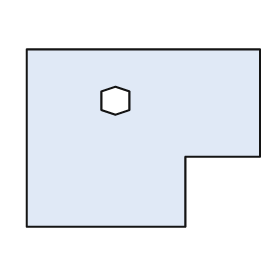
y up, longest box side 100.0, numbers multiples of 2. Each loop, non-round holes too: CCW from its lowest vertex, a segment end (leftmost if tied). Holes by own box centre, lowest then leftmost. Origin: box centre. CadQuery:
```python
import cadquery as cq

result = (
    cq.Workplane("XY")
    .moveTo(-50.0, -38.0)
    .lineTo(18.0, -38.0)
    .lineTo(18.0, -8.0)
    .lineTo(50.0, -8.0)
    .lineTo(50.0, 38.0)
    .lineTo(-50.0, 38.0)
    .close()
    .moveTo(-12.0, 10.0)
    .lineTo(-6.0, 12.0)
    .lineTo(-6.0, 20.0)
    .lineTo(-12.0, 22.0)
    .lineTo(-18.0, 20.0)
    .lineTo(-18.0, 12.0)
    .close()
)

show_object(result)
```